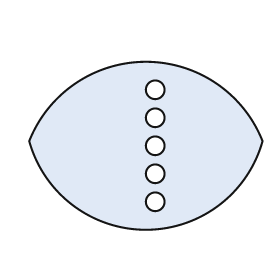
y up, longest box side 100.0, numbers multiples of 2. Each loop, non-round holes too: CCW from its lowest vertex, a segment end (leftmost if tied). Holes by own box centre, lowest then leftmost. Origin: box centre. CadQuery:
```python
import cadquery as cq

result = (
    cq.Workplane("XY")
    .moveTo(-50.0, 2.0)
    .threePointArc((0.0, -36.0), (50.0, 2.0))
    .threePointArc((0.0, 36.0), (-50.0, 2.0))
    .close()
    .moveTo(4.0, -24.0)
    .circle(4.0)
    .moveTo(4.0, -12.0)
    .circle(4.0)
    .moveTo(4.0, 0.0)
    .circle(4.0)
    .moveTo(4.0, 12.0)
    .circle(4.0)
    .moveTo(4.0, 24.0)
    .circle(4.0)
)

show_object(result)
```